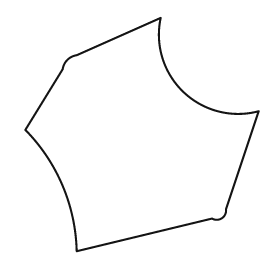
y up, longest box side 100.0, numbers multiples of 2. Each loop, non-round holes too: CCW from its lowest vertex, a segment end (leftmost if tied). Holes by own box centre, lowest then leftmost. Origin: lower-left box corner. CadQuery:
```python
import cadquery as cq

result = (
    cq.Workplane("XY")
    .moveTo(22.0, 0.0)
    .lineTo(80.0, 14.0)
    .threePointArc((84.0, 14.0), (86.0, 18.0))
    .lineTo(100.0, 60.0)
    .threePointArc((68.0, 68.0), (58.0, 100.0))
    .lineTo(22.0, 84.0)
    .threePointArc((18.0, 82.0), (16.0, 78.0))
    .lineTo(0.0, 52.0)
    .threePointArc((16.0, 28.0), (22.0, 0.0))
    .close()
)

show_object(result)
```